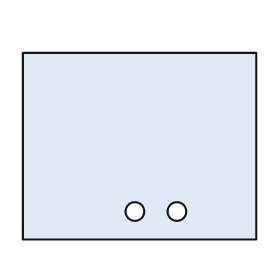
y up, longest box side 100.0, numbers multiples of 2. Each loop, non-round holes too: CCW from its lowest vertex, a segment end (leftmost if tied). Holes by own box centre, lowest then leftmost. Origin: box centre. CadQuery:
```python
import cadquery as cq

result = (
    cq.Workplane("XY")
    .moveTo(-50.0, -40.0)
    .lineTo(50.0, -40.0)
    .lineTo(50.0, 40.0)
    .lineTo(-50.0, 40.0)
    .close()
    .moveTo(-2.0, -28.0)
    .circle(4.0)
    .moveTo(16.0, -28.0)
    .circle(4.0)
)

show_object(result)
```